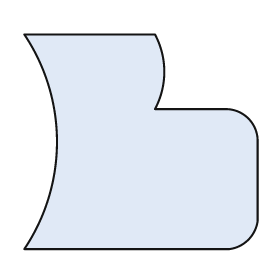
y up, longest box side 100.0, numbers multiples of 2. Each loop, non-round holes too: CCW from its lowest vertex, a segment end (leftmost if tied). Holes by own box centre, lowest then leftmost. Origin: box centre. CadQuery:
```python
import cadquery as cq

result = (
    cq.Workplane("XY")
    .moveTo(-50.0, -46.0)
    .lineTo(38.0, -46.0)
    .threePointArc((46.0, -42.0), (50.0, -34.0))
    .lineTo(50.0, 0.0)
    .threePointArc((46.0, 10.0), (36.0, 14.0))
    .lineTo(6.0, 14.0)
    .threePointArc((10.0, 30.0), (6.0, 46.0))
    .lineTo(-50.0, 46.0)
    .threePointArc((-36.0, 0.0), (-50.0, -46.0))
    .close()
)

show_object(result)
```